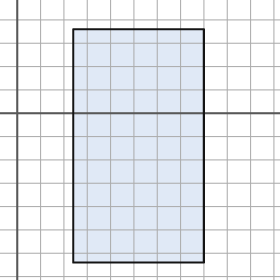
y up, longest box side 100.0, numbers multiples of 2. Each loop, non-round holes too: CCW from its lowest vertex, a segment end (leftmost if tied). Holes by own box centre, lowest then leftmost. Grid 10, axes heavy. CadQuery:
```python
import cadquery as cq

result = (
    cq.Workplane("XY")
    .moveTo(24.0, -64.0)
    .lineTo(80.0, -64.0)
    .lineTo(80.0, 36.0)
    .lineTo(24.0, 36.0)
    .close()
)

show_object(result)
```